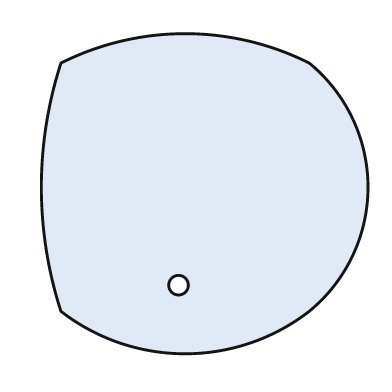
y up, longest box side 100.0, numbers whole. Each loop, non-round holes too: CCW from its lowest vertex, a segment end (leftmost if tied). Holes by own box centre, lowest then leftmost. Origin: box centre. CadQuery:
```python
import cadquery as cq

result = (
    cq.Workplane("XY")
    .moveTo(-44.0, -36.0)
    .threePointArc((-6.0, -49.0), (32.0, -36.0))
    .threePointArc((50.0, 2.0), (32.0, 40.0))
    .threePointArc((-6.0, 49.0), (-44.0, 40.0))
    .threePointArc((-50.0, 2.0), (-44.0, -36.0))
    .close()
    .moveTo(-8.0, -28.0)
    .circle(3.0)
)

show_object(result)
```